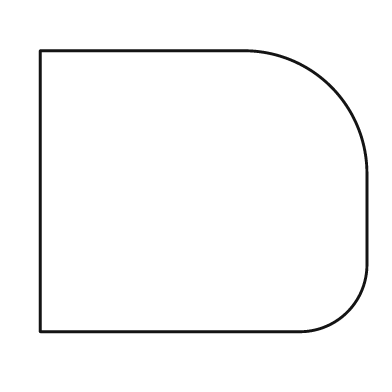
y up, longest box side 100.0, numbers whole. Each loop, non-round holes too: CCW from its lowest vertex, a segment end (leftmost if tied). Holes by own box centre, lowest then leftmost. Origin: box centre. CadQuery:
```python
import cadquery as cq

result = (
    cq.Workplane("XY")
    .moveTo(-50.0, -43.0)
    .lineTo(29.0, -43.0)
    .threePointArc((44.0, -37.0), (50.0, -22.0))
    .lineTo(50.0, 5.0)
    .threePointArc((39.0, 32.0), (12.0, 43.0))
    .lineTo(-50.0, 43.0)
    .close()
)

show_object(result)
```